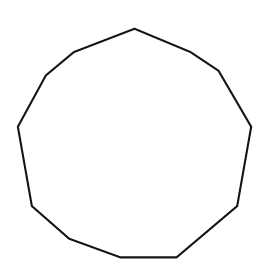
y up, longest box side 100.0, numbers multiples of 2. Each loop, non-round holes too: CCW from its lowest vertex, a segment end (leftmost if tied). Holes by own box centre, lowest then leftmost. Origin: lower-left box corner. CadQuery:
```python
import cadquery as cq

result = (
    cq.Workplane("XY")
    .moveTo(44.0, 0.0)
    .lineTo(68.0, 0.0)
    .lineTo(94.0, 22.0)
    .lineTo(100.0, 56.0)
    .lineTo(86.0, 80.0)
    .lineTo(74.0, 88.0)
    .lineTo(50.0, 98.0)
    .lineTo(24.0, 88.0)
    .lineTo(12.0, 78.0)
    .lineTo(0.0, 56.0)
    .lineTo(6.0, 22.0)
    .lineTo(22.0, 8.0)
    .close()
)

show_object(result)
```